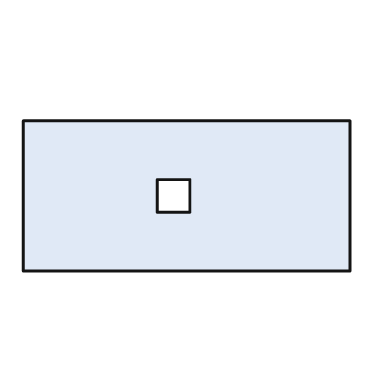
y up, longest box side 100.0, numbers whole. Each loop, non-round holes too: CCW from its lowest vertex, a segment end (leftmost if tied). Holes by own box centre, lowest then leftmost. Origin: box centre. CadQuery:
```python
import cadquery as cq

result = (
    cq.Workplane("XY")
    .moveTo(-50.0, -23.0)
    .lineTo(50.0, -23.0)
    .lineTo(50.0, 23.0)
    .lineTo(-50.0, 23.0)
    .close()
    .moveTo(-9.0, -5.0)
    .lineTo(1.0, -5.0)
    .lineTo(1.0, 5.0)
    .lineTo(-9.0, 5.0)
    .close()
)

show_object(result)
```